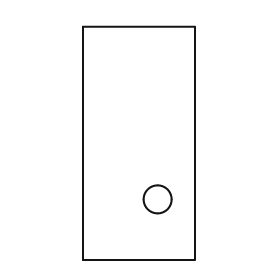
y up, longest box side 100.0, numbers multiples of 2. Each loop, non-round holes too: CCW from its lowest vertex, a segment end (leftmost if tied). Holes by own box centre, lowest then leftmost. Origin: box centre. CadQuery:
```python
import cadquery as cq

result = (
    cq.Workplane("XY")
    .moveTo(-24.0, -50.0)
    .lineTo(24.0, -50.0)
    .lineTo(24.0, 50.0)
    .lineTo(-24.0, 50.0)
    .close()
    .moveTo(8.0, -24.0)
    .circle(6.0)
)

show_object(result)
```